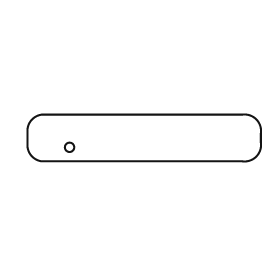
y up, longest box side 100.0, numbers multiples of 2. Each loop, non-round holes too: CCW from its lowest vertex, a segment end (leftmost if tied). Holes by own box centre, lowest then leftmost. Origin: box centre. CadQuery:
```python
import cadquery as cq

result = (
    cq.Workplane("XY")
    .moveTo(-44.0, -10.0)
    .lineTo(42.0, -10.0)
    .threePointArc((48.0, -8.0), (50.0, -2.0))
    .lineTo(50.0, 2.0)
    .threePointArc((48.0, 8.0), (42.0, 10.0))
    .lineTo(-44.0, 10.0)
    .threePointArc((-48.0, 8.0), (-50.0, 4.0))
    .lineTo(-50.0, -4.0)
    .threePointArc((-48.0, -8.0), (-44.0, -10.0))
    .close()
    .moveTo(-32.0, -4.0)
    .circle(2.0)
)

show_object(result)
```